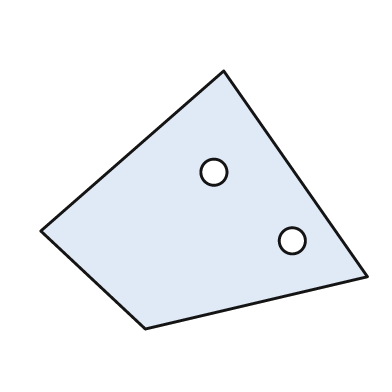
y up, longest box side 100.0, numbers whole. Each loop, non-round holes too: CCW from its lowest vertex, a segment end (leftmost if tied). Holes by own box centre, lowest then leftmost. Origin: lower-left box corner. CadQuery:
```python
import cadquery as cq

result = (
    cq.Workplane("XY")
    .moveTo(32.0, 0.0)
    .lineTo(100.0, 16.0)
    .lineTo(56.0, 79.0)
    .lineTo(0.0, 30.0)
    .close()
    .moveTo(77.0, 27.0)
    .circle(4.0)
    .moveTo(53.0, 48.0)
    .circle(4.0)
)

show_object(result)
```